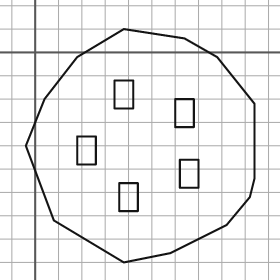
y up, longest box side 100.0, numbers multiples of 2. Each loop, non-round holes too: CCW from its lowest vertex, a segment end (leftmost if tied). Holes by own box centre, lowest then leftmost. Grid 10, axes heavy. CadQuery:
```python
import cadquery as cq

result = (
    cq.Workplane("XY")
    .moveTo(38.0, -90.0)
    .lineTo(58.0, -86.0)
    .lineTo(82.0, -74.0)
    .lineTo(92.0, -62.0)
    .lineTo(94.0, -54.0)
    .lineTo(94.0, -22.0)
    .lineTo(78.0, -2.0)
    .lineTo(64.0, 6.0)
    .lineTo(38.0, 10.0)
    .lineTo(18.0, -2.0)
    .lineTo(4.0, -20.0)
    .lineTo(-4.0, -40.0)
    .lineTo(8.0, -72.0)
    .close()
    .moveTo(36.0, -68.0)
    .lineTo(44.0, -68.0)
    .lineTo(44.0, -56.0)
    .lineTo(36.0, -56.0)
    .close()
    .moveTo(62.0, -58.0)
    .lineTo(70.0, -58.0)
    .lineTo(70.0, -46.0)
    .lineTo(62.0, -46.0)
    .close()
    .moveTo(18.0, -48.0)
    .lineTo(26.0, -48.0)
    .lineTo(26.0, -36.0)
    .lineTo(18.0, -36.0)
    .close()
    .moveTo(60.0, -32.0)
    .lineTo(68.0, -32.0)
    .lineTo(68.0, -20.0)
    .lineTo(60.0, -20.0)
    .close()
    .moveTo(34.0, -24.0)
    .lineTo(42.0, -24.0)
    .lineTo(42.0, -12.0)
    .lineTo(34.0, -12.0)
    .close()
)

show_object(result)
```